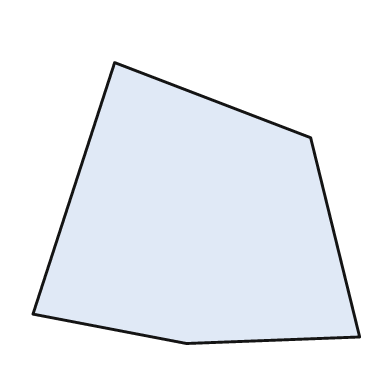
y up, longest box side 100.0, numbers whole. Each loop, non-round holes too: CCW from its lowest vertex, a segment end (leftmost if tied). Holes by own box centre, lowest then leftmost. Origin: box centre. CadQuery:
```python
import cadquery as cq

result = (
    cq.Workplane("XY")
    .moveTo(-3.0, -43.0)
    .lineTo(50.0, -41.0)
    .lineTo(35.0, 20.0)
    .lineTo(-25.0, 43.0)
    .lineTo(-50.0, -34.0)
    .close()
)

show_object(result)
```